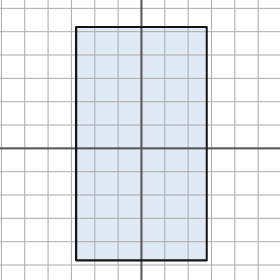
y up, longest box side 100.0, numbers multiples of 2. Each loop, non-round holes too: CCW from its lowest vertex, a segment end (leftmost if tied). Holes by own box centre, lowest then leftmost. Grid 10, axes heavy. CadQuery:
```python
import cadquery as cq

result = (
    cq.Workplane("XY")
    .moveTo(-28.0, -48.0)
    .lineTo(28.0, -48.0)
    .lineTo(28.0, 52.0)
    .lineTo(-28.0, 52.0)
    .close()
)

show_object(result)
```